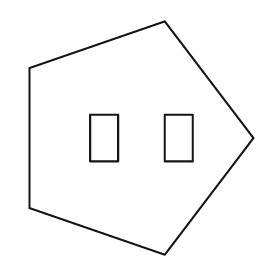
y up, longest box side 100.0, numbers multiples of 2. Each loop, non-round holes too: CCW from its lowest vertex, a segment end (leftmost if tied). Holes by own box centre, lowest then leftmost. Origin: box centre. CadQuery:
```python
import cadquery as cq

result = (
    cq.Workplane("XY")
    .moveTo(10.0, -50.0)
    .lineTo(48.0, 0.0)
    .lineTo(10.0, 50.0)
    .lineTo(-48.0, 30.0)
    .lineTo(-48.0, -30.0)
    .close()
    .moveTo(-22.0, -10.0)
    .lineTo(-10.0, -10.0)
    .lineTo(-10.0, 10.0)
    .lineTo(-22.0, 10.0)
    .close()
    .moveTo(10.0, -10.0)
    .lineTo(22.0, -10.0)
    .lineTo(22.0, 10.0)
    .lineTo(10.0, 10.0)
    .close()
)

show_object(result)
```